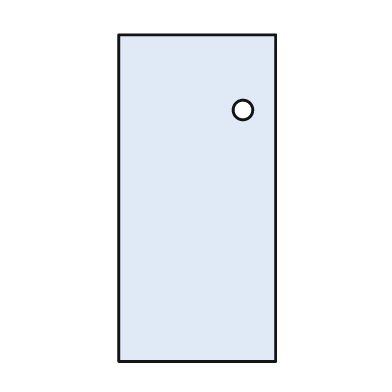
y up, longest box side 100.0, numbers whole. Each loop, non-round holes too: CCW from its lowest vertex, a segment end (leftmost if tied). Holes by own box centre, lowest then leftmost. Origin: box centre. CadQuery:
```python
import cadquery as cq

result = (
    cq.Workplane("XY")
    .moveTo(-24.0, -50.0)
    .lineTo(24.0, -50.0)
    .lineTo(24.0, 50.0)
    .lineTo(-24.0, 50.0)
    .close()
    .moveTo(14.0, 27.0)
    .circle(3.0)
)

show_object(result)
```